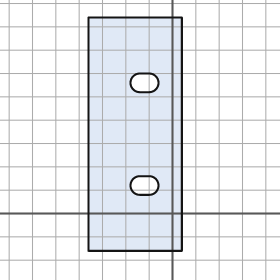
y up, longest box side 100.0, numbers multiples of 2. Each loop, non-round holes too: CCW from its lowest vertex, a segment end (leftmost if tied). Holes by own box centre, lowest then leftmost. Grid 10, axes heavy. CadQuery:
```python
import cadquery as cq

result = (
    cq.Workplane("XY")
    .moveTo(-36.0, -16.0)
    .lineTo(4.0, -16.0)
    .lineTo(4.0, 84.0)
    .lineTo(-36.0, 84.0)
    .close()
    .moveTo(-14.0, 8.0)
    .lineTo(-10.0, 8.0)
    .threePointArc((-6.0, 12.0), (-10.0, 16.0))
    .lineTo(-14.0, 16.0)
    .threePointArc((-18.0, 12.0), (-14.0, 8.0))
    .close()
    .moveTo(-14.0, 52.0)
    .lineTo(-10.0, 52.0)
    .threePointArc((-6.0, 56.0), (-10.0, 60.0))
    .lineTo(-14.0, 60.0)
    .threePointArc((-18.0, 56.0), (-14.0, 52.0))
    .close()
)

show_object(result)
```